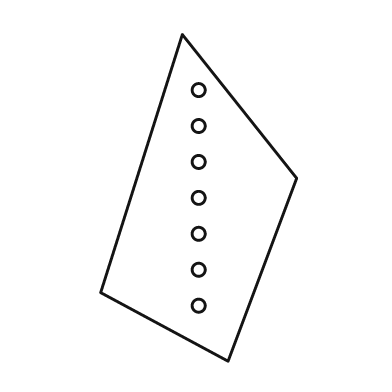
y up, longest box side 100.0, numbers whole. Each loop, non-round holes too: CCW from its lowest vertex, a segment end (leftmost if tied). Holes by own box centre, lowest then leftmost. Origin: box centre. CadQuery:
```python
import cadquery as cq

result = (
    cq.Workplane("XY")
    .moveTo(9.0, -50.0)
    .lineTo(30.0, 6.0)
    .lineTo(-5.0, 50.0)
    .lineTo(-30.0, -29.0)
    .close()
    .moveTo(0.0, -33.0)
    .circle(2.0)
    .moveTo(0.0, -22.0)
    .circle(2.0)
    .moveTo(0.0, -11.0)
    .circle(2.0)
    .moveTo(0.0, 0.0)
    .circle(2.0)
    .moveTo(0.0, 11.0)
    .circle(2.0)
    .moveTo(0.0, 22.0)
    .circle(2.0)
    .moveTo(0.0, 33.0)
    .circle(2.0)
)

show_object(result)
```